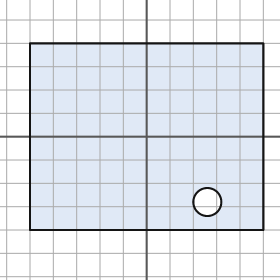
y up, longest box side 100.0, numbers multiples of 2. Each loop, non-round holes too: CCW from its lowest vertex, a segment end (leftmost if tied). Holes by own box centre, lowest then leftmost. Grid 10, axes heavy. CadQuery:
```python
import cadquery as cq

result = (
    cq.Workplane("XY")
    .moveTo(-50.0, -40.0)
    .lineTo(50.0, -40.0)
    .lineTo(50.0, 40.0)
    .lineTo(-50.0, 40.0)
    .close()
    .moveTo(26.0, -28.0)
    .circle(6.0)
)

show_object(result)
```